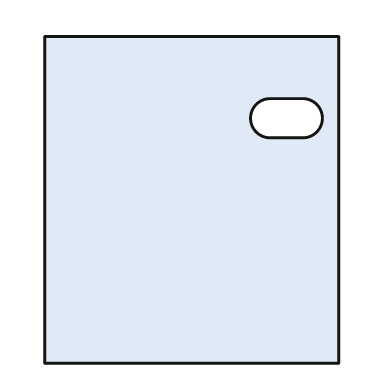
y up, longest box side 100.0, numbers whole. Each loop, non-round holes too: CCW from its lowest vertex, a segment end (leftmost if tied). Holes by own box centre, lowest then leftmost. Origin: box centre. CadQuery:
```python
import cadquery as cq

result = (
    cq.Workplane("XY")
    .moveTo(-45.0, -50.0)
    .lineTo(45.0, -50.0)
    .lineTo(45.0, 50.0)
    .lineTo(-45.0, 50.0)
    .close()
    .moveTo(24.0, 19.0)
    .lineTo(34.0, 19.0)
    .threePointArc((40.0, 25.0), (34.0, 31.0))
    .lineTo(24.0, 31.0)
    .threePointArc((18.0, 25.0), (24.0, 19.0))
    .close()
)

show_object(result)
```